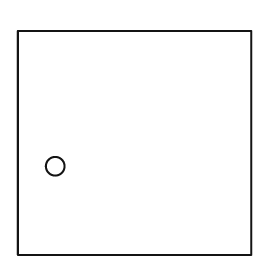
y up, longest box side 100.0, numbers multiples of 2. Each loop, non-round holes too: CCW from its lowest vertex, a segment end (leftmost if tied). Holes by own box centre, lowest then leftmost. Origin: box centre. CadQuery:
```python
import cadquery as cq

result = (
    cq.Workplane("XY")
    .moveTo(-50.0, -48.0)
    .lineTo(50.0, -48.0)
    .lineTo(50.0, 48.0)
    .lineTo(-50.0, 48.0)
    .close()
    .moveTo(-34.0, -10.0)
    .circle(4.0)
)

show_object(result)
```